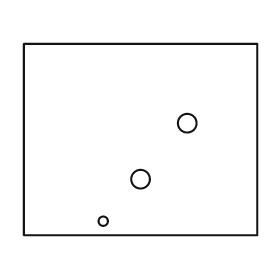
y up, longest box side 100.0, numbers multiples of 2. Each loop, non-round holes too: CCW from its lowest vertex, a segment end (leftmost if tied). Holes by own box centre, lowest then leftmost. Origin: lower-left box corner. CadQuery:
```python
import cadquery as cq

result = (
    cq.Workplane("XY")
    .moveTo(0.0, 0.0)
    .lineTo(100.0, 0.0)
    .lineTo(100.0, 82.0)
    .lineTo(0.0, 82.0)
    .close()
    .moveTo(34.0, 6.0)
    .circle(2.0)
    .moveTo(50.0, 24.0)
    .circle(4.0)
    .moveTo(70.0, 48.0)
    .circle(4.0)
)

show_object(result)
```